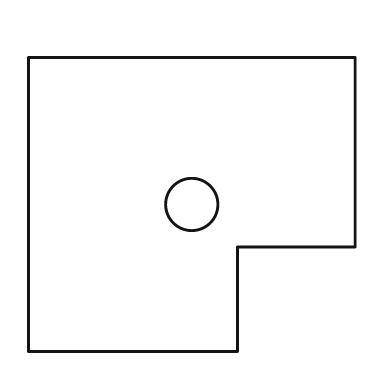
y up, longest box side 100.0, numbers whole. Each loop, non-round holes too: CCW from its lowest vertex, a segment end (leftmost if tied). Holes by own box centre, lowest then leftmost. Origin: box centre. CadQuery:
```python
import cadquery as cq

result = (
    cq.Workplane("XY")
    .moveTo(-50.0, -45.0)
    .lineTo(14.0, -45.0)
    .lineTo(14.0, -13.0)
    .lineTo(50.0, -13.0)
    .lineTo(50.0, 45.0)
    .lineTo(-50.0, 45.0)
    .close()
    .moveTo(0.0, 0.0)
    .circle(8.0)
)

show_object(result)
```